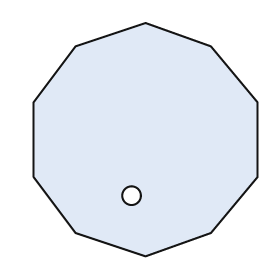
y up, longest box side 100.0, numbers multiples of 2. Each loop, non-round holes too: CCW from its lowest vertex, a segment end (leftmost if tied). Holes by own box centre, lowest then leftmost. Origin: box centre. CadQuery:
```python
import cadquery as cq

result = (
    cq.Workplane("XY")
    .moveTo(0.0, -50.0)
    .lineTo(28.0, -40.0)
    .lineTo(48.0, -16.0)
    .lineTo(48.0, 16.0)
    .lineTo(28.0, 40.0)
    .lineTo(0.0, 50.0)
    .lineTo(-30.0, 40.0)
    .lineTo(-48.0, 16.0)
    .lineTo(-48.0, -16.0)
    .lineTo(-30.0, -40.0)
    .close()
    .moveTo(-6.0, -24.0)
    .circle(4.0)
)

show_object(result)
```